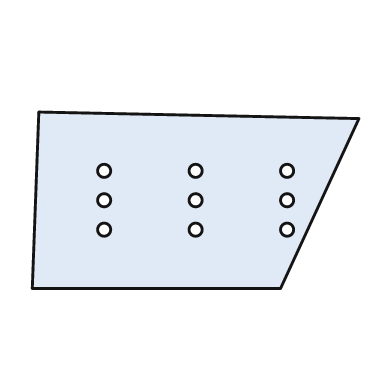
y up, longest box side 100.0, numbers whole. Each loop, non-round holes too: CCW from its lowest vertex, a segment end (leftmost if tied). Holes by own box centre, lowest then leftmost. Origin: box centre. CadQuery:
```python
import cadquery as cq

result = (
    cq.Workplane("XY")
    .moveTo(-50.0, -27.0)
    .lineTo(26.0, -27.0)
    .lineTo(50.0, 25.0)
    .lineTo(-48.0, 27.0)
    .close()
    .moveTo(-28.0, -9.0)
    .circle(2.0)
    .moveTo(0.0, -9.0)
    .circle(2.0)
    .moveTo(28.0, -9.0)
    .circle(2.0)
    .moveTo(-28.0, 0.0)
    .circle(2.0)
    .moveTo(0.0, 0.0)
    .circle(2.0)
    .moveTo(28.0, 0.0)
    .circle(2.0)
    .moveTo(-28.0, 9.0)
    .circle(2.0)
    .moveTo(0.0, 9.0)
    .circle(2.0)
    .moveTo(28.0, 9.0)
    .circle(2.0)
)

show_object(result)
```